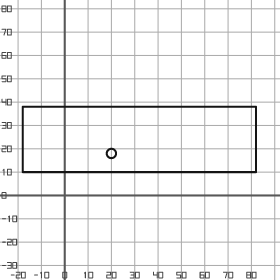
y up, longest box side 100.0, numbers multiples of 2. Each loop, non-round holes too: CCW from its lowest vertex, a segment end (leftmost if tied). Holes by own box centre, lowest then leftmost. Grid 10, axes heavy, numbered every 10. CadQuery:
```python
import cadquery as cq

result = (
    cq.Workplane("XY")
    .moveTo(-18.0, 10.0)
    .lineTo(82.0, 10.0)
    .lineTo(82.0, 38.0)
    .lineTo(-18.0, 38.0)
    .close()
    .moveTo(20.0, 18.0)
    .circle(2.0)
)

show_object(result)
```